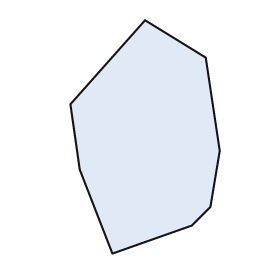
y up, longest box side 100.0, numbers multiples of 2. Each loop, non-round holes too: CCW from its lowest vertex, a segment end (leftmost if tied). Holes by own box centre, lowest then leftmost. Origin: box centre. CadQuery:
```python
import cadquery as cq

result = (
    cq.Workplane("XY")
    .moveTo(-14.0, -50.0)
    .lineTo(20.0, -38.0)
    .lineTo(28.0, -30.0)
    .lineTo(32.0, -6.0)
    .lineTo(26.0, 34.0)
    .lineTo(0.0, 50.0)
    .lineTo(-32.0, 14.0)
    .lineTo(-28.0, -14.0)
    .close()
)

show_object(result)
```